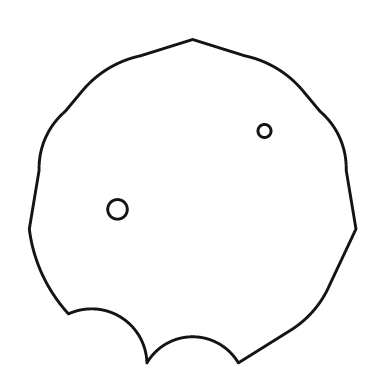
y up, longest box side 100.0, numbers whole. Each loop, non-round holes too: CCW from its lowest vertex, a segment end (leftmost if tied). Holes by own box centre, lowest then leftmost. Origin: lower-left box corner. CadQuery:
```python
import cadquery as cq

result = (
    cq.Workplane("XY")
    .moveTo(36.0, 0.0)
    .threePointArc((50.0, 8.0), (64.0, 0.0))
    .lineTo(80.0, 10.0)
    .threePointArc((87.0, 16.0), (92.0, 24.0))
    .lineTo(100.0, 41.0)
    .lineTo(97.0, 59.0)
    .threePointArc((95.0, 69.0), (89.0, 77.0))
    .lineTo(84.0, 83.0)
    .threePointArc((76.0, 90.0), (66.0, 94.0))
    .lineTo(50.0, 99.0)
    .lineTo(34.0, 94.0)
    .threePointArc((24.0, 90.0), (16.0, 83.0))
    .lineTo(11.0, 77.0)
    .threePointArc((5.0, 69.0), (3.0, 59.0))
    .lineTo(0.0, 41.0)
    .threePointArc((4.0, 27.0), (12.0, 15.0))
    .threePointArc((28.0, 14.0), (36.0, 0.0))
    .close()
    .moveTo(27.0, 47.0)
    .circle(3.0)
    .moveTo(72.0, 71.0)
    .circle(2.0)
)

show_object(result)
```